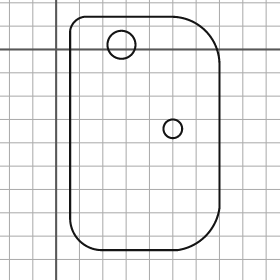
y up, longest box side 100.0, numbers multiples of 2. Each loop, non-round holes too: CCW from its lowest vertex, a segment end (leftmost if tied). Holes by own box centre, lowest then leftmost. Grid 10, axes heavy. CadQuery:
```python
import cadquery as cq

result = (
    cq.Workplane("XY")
    .moveTo(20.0, -86.0)
    .lineTo(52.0, -86.0)
    .threePointArc((64.0, -80.0), (70.0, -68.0))
    .lineTo(70.0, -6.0)
    .threePointArc((64.0, 8.0), (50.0, 14.0))
    .lineTo(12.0, 14.0)
    .threePointArc((8.0, 12.0), (6.0, 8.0))
    .lineTo(6.0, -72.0)
    .threePointArc((10.0, -82.0), (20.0, -86.0))
    .close()
    .moveTo(50.0, -34.0)
    .circle(4.0)
    .moveTo(28.0, 2.0)
    .circle(6.0)
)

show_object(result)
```